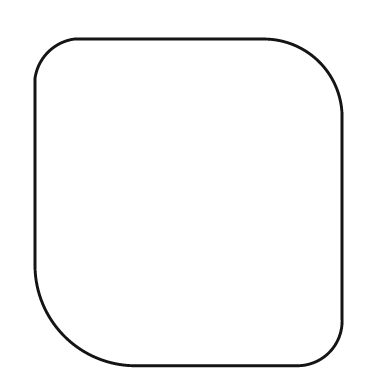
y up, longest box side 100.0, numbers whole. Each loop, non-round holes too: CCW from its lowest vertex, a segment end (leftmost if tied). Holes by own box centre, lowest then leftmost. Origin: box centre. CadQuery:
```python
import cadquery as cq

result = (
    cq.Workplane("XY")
    .moveTo(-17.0, -50.0)
    .lineTo(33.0, -50.0)
    .threePointArc((43.0, -46.0), (47.0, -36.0))
    .lineTo(47.0, 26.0)
    .threePointArc((40.0, 43.0), (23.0, 50.0))
    .lineTo(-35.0, 50.0)
    .threePointArc((-43.0, 46.0), (-47.0, 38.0))
    .lineTo(-47.0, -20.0)
    .threePointArc((-38.0, -41.0), (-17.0, -50.0))
    .close()
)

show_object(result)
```